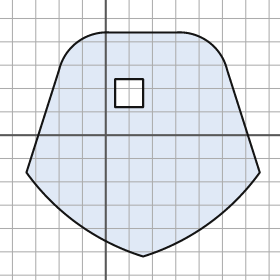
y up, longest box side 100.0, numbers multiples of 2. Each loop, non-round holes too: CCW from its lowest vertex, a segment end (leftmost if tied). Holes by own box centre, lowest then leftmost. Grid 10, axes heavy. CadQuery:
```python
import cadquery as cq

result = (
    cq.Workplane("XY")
    .moveTo(16.0, -52.0)
    .threePointArc((44.0, -38.0), (66.0, -16.0))
    .lineTo(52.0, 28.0)
    .threePointArc((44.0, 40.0), (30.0, 44.0))
    .lineTo(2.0, 44.0)
    .threePointArc((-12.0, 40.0), (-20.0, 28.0))
    .lineTo(-34.0, -16.0)
    .threePointArc((-12.0, -38.0), (16.0, -52.0))
    .close()
    .moveTo(4.0, 12.0)
    .lineTo(16.0, 12.0)
    .lineTo(16.0, 24.0)
    .lineTo(4.0, 24.0)
    .close()
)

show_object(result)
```